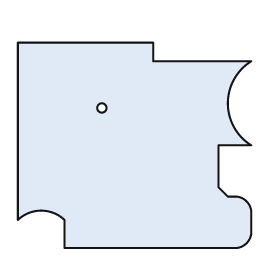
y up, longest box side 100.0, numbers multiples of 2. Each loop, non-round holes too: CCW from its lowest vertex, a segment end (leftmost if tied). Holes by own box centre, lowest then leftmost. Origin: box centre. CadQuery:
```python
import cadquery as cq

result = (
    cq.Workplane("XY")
    .moveTo(-30.0, -44.0)
    .lineTo(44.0, -44.0)
    .threePointArc((48.0, -42.0), (50.0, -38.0))
    .lineTo(50.0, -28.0)
    .threePointArc((48.0, -24.0), (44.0, -22.0))
    .lineTo(40.0, -22.0)
    .lineTo(36.0, -18.0)
    .lineTo(36.0, 0.0)
    .lineTo(50.0, 0.0)
    .threePointArc((40.0, 18.0), (50.0, 36.0))
    .lineTo(8.0, 36.0)
    .lineTo(8.0, 44.0)
    .lineTo(-50.0, 44.0)
    .lineTo(-50.0, -32.0)
    .threePointArc((-40.0, -28.0), (-30.0, -32.0))
    .close()
    .moveTo(-14.0, 16.0)
    .circle(2.0)
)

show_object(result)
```